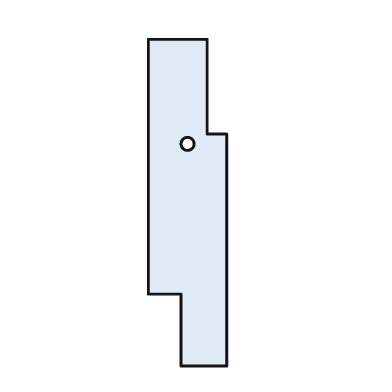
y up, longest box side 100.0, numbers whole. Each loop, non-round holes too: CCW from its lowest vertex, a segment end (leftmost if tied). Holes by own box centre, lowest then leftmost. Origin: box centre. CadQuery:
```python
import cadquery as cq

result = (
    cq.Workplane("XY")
    .moveTo(-2.0, -50.0)
    .lineTo(12.0, -50.0)
    .lineTo(12.0, 21.0)
    .lineTo(6.0, 21.0)
    .lineTo(6.0, 50.0)
    .lineTo(-12.0, 50.0)
    .lineTo(-12.0, -28.0)
    .lineTo(-2.0, -28.0)
    .close()
    .moveTo(0.0, 18.0)
    .circle(2.0)
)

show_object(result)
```